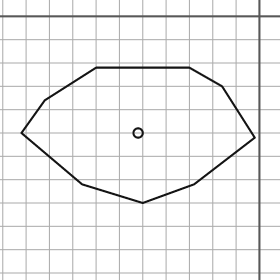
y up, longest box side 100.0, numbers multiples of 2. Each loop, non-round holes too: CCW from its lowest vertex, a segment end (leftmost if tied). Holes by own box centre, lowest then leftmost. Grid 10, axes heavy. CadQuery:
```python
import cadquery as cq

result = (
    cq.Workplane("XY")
    .moveTo(-50.0, -80.0)
    .lineTo(-28.0, -72.0)
    .lineTo(-2.0, -52.0)
    .lineTo(-16.0, -30.0)
    .lineTo(-30.0, -22.0)
    .lineTo(-70.0, -22.0)
    .lineTo(-92.0, -36.0)
    .lineTo(-102.0, -50.0)
    .lineTo(-76.0, -72.0)
    .close()
    .moveTo(-52.0, -50.0)
    .circle(2.0)
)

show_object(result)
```